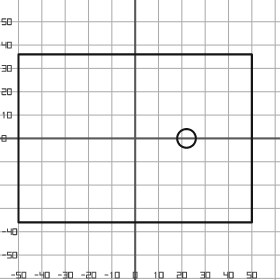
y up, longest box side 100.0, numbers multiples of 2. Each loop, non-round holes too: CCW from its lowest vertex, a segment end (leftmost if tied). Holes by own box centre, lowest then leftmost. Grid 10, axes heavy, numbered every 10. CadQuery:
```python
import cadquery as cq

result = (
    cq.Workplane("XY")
    .moveTo(-50.0, -36.0)
    .lineTo(50.0, -36.0)
    .lineTo(50.0, 36.0)
    .lineTo(-50.0, 36.0)
    .close()
    .moveTo(22.0, 0.0)
    .circle(4.0)
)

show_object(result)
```